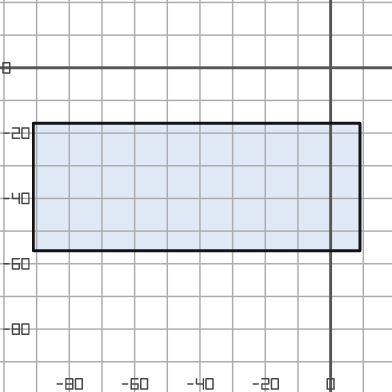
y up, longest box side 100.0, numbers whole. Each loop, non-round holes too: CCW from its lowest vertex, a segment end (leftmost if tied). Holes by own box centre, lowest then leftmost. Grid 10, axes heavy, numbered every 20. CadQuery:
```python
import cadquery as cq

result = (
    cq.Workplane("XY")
    .moveTo(-91.0, -56.0)
    .lineTo(9.0, -56.0)
    .lineTo(9.0, -17.0)
    .lineTo(-91.0, -17.0)
    .close()
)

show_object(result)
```